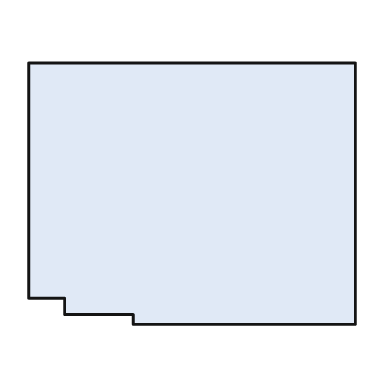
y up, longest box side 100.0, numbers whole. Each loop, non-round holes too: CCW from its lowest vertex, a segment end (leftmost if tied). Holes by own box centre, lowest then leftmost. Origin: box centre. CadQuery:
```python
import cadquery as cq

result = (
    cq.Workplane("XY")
    .moveTo(-18.0, -40.0)
    .lineTo(50.0, -40.0)
    .lineTo(50.0, 40.0)
    .lineTo(-50.0, 40.0)
    .lineTo(-50.0, -32.0)
    .lineTo(-39.0, -32.0)
    .lineTo(-39.0, -37.0)
    .lineTo(-18.0, -37.0)
    .close()
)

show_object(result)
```